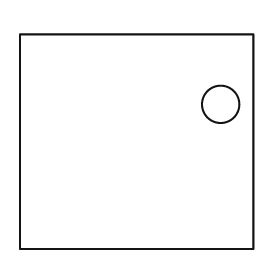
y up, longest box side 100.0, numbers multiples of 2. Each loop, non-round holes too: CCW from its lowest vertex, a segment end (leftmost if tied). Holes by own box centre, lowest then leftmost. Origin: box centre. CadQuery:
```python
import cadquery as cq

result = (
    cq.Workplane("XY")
    .moveTo(-50.0, -46.0)
    .lineTo(50.0, -46.0)
    .lineTo(50.0, 46.0)
    .lineTo(-50.0, 46.0)
    .close()
    .moveTo(36.0, 16.0)
    .circle(8.0)
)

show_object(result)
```